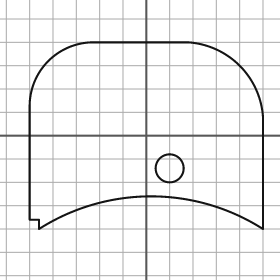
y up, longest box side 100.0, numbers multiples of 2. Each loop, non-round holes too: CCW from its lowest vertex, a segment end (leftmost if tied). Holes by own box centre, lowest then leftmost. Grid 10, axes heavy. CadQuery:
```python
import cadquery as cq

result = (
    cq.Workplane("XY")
    .moveTo(-46.0, -40.0)
    .threePointArc((2.0, -26.0), (50.0, -40.0))
    .lineTo(50.0, 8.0)
    .threePointArc((40.0, 30.0), (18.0, 40.0))
    .lineTo(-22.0, 40.0)
    .threePointArc((-42.0, 32.0), (-50.0, 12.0))
    .lineTo(-50.0, -36.0)
    .lineTo(-46.0, -36.0)
    .close()
    .moveTo(10.0, -14.0)
    .circle(6.0)
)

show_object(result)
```